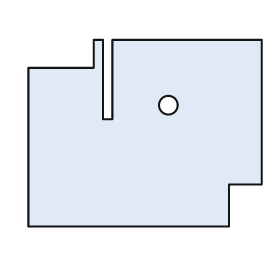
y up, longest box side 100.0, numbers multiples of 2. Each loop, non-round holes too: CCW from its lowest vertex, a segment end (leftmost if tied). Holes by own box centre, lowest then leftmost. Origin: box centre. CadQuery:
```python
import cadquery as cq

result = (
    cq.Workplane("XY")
    .moveTo(-50.0, -40.0)
    .lineTo(36.0, -40.0)
    .lineTo(36.0, -22.0)
    .lineTo(50.0, -22.0)
    .lineTo(50.0, 40.0)
    .lineTo(-14.0, 40.0)
    .lineTo(-14.0, 6.0)
    .lineTo(-18.0, 6.0)
    .lineTo(-18.0, 40.0)
    .lineTo(-22.0, 40.0)
    .lineTo(-22.0, 28.0)
    .lineTo(-50.0, 28.0)
    .close()
    .moveTo(10.0, 12.0)
    .circle(4.0)
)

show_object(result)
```